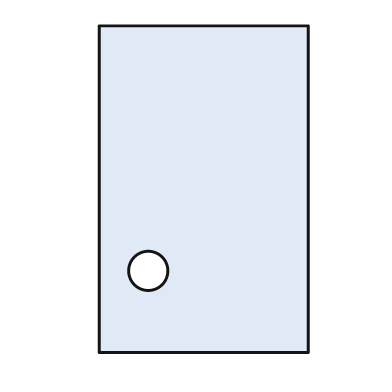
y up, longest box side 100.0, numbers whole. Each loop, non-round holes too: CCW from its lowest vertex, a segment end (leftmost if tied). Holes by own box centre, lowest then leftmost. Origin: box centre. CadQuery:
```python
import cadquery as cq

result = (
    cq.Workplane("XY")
    .moveTo(-32.0, -50.0)
    .lineTo(32.0, -50.0)
    .lineTo(32.0, 50.0)
    .lineTo(-32.0, 50.0)
    .close()
    .moveTo(-17.0, -25.0)
    .circle(6.0)
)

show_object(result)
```